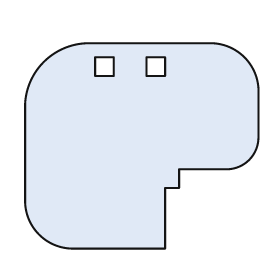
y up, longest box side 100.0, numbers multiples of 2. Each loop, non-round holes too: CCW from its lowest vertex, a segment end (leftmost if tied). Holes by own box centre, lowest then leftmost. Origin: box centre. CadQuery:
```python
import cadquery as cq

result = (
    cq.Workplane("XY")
    .moveTo(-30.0, -44.0)
    .lineTo(10.0, -44.0)
    .lineTo(10.0, -18.0)
    .lineTo(16.0, -18.0)
    .lineTo(16.0, -10.0)
    .lineTo(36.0, -10.0)
    .threePointArc((46.0, -6.0), (50.0, 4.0))
    .lineTo(50.0, 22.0)
    .threePointArc((44.0, 38.0), (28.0, 44.0))
    .lineTo(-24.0, 44.0)
    .threePointArc((-42.0, 36.0), (-50.0, 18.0))
    .lineTo(-50.0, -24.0)
    .threePointArc((-44.0, -38.0), (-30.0, -44.0))
    .close()
    .moveTo(-20.0, 30.0)
    .lineTo(-12.0, 30.0)
    .lineTo(-12.0, 38.0)
    .lineTo(-20.0, 38.0)
    .close()
    .moveTo(2.0, 30.0)
    .lineTo(10.0, 30.0)
    .lineTo(10.0, 38.0)
    .lineTo(2.0, 38.0)
    .close()
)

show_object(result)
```